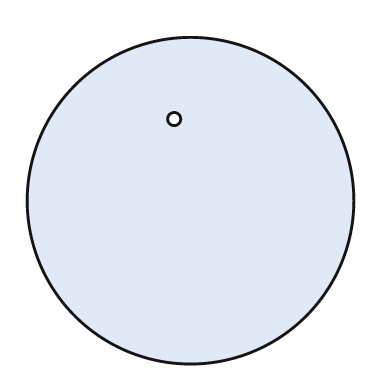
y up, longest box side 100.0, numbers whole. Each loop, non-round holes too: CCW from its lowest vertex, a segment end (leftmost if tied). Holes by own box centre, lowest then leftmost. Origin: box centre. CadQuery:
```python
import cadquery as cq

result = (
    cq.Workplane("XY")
    .moveTo(0.0, 0.0)
    .circle(50.0)
    .moveTo(-5.0, 25.0)
    .circle(2.0)
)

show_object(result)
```